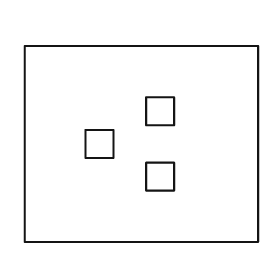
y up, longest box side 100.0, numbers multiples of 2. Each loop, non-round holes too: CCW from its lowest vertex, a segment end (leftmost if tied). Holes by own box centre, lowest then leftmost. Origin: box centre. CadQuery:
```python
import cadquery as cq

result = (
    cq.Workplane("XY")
    .moveTo(-50.0, -42.0)
    .lineTo(50.0, -42.0)
    .lineTo(50.0, 42.0)
    .lineTo(-50.0, 42.0)
    .close()
    .moveTo(2.0, -20.0)
    .lineTo(14.0, -20.0)
    .lineTo(14.0, -8.0)
    .lineTo(2.0, -8.0)
    .close()
    .moveTo(-24.0, -6.0)
    .lineTo(-12.0, -6.0)
    .lineTo(-12.0, 6.0)
    .lineTo(-24.0, 6.0)
    .close()
    .moveTo(2.0, 8.0)
    .lineTo(14.0, 8.0)
    .lineTo(14.0, 20.0)
    .lineTo(2.0, 20.0)
    .close()
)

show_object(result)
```